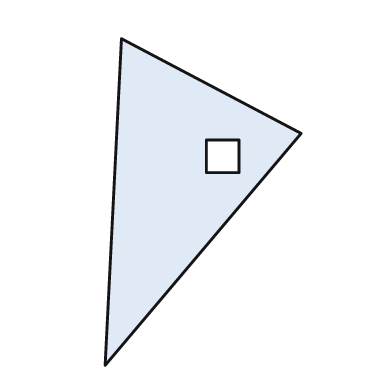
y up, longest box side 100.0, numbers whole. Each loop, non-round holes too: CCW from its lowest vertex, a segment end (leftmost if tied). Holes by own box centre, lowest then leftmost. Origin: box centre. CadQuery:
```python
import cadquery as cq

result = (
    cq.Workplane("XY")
    .moveTo(-30.0, -50.0)
    .lineTo(30.0, 21.0)
    .lineTo(-25.0, 50.0)
    .close()
    .moveTo(1.0, 9.0)
    .lineTo(11.0, 9.0)
    .lineTo(11.0, 19.0)
    .lineTo(1.0, 19.0)
    .close()
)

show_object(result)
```